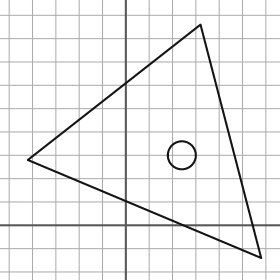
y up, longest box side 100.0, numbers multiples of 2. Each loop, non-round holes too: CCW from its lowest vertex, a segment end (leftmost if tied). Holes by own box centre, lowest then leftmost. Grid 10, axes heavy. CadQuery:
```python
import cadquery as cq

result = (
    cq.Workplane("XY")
    .moveTo(58.0, -14.0)
    .lineTo(32.0, 86.0)
    .lineTo(-42.0, 28.0)
    .close()
    .moveTo(24.0, 30.0)
    .circle(6.0)
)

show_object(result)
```